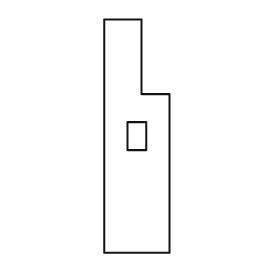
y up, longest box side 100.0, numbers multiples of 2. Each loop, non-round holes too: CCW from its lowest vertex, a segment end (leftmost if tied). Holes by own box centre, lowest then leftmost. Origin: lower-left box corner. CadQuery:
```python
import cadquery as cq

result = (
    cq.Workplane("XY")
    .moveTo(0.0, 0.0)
    .lineTo(28.0, 0.0)
    .lineTo(28.0, 68.0)
    .lineTo(16.0, 68.0)
    .lineTo(16.0, 100.0)
    .lineTo(0.0, 100.0)
    .close()
    .moveTo(10.0, 44.0)
    .lineTo(18.0, 44.0)
    .lineTo(18.0, 56.0)
    .lineTo(10.0, 56.0)
    .close()
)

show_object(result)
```